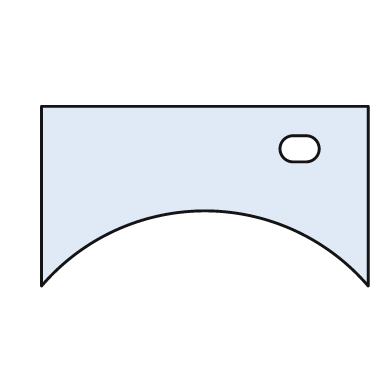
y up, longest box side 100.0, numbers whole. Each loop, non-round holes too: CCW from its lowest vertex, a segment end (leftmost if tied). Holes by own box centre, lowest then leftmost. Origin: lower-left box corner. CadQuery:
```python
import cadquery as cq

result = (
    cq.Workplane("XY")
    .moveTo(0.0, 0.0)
    .threePointArc((50.0, 23.0), (100.0, 0.0))
    .lineTo(100.0, 55.0)
    .lineTo(0.0, 55.0)
    .close()
    .moveTo(77.0, 38.0)
    .lineTo(81.0, 38.0)
    .threePointArc((85.0, 42.0), (81.0, 46.0))
    .lineTo(77.0, 46.0)
    .threePointArc((73.0, 42.0), (77.0, 38.0))
    .close()
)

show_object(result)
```